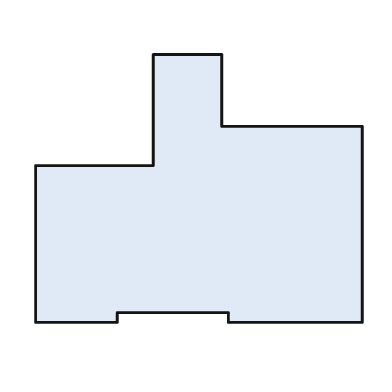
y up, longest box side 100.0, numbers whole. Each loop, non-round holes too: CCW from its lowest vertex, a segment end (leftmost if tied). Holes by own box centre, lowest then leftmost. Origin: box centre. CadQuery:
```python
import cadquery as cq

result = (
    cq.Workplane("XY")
    .moveTo(-50.0, -41.0)
    .lineTo(-25.0, -41.0)
    .lineTo(-25.0, -38.0)
    .lineTo(9.0, -38.0)
    .lineTo(9.0, -41.0)
    .lineTo(50.0, -41.0)
    .lineTo(50.0, 19.0)
    .lineTo(7.0, 19.0)
    .lineTo(7.0, 41.0)
    .lineTo(-14.0, 41.0)
    .lineTo(-14.0, 7.0)
    .lineTo(-50.0, 7.0)
    .close()
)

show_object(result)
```